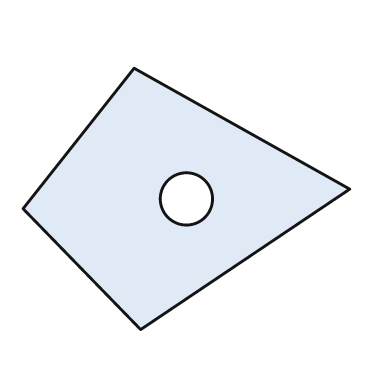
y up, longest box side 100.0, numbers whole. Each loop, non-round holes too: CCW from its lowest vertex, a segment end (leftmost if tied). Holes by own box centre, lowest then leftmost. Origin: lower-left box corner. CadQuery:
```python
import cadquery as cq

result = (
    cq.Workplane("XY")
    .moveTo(36.0, 0.0)
    .lineTo(100.0, 43.0)
    .lineTo(34.0, 80.0)
    .lineTo(0.0, 37.0)
    .close()
    .moveTo(50.0, 40.0)
    .circle(8.0)
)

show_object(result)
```